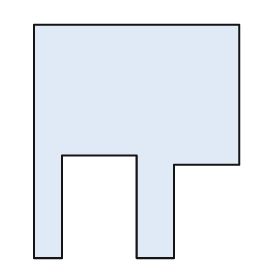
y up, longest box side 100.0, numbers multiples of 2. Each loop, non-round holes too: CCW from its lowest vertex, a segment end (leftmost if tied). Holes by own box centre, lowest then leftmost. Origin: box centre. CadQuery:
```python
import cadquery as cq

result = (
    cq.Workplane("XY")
    .moveTo(-44.0, -50.0)
    .lineTo(-32.0, -50.0)
    .lineTo(-32.0, -6.0)
    .lineTo(0.0, -6.0)
    .lineTo(0.0, -50.0)
    .lineTo(16.0, -50.0)
    .lineTo(16.0, -10.0)
    .lineTo(44.0, -10.0)
    .lineTo(44.0, 50.0)
    .lineTo(-44.0, 50.0)
    .close()
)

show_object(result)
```